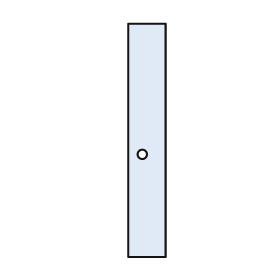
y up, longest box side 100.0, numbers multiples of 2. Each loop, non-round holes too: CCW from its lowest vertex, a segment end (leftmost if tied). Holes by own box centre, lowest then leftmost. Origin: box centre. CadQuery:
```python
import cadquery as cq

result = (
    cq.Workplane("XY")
    .moveTo(-8.0, -50.0)
    .lineTo(8.0, -50.0)
    .lineTo(8.0, 50.0)
    .lineTo(-8.0, 50.0)
    .close()
    .moveTo(-2.0, -6.0)
    .circle(2.0)
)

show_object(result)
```